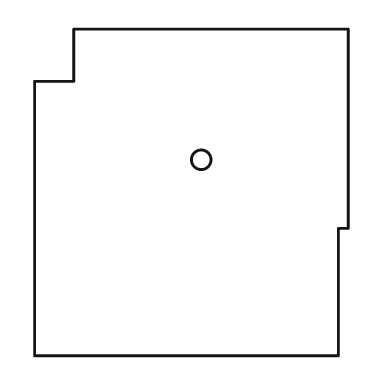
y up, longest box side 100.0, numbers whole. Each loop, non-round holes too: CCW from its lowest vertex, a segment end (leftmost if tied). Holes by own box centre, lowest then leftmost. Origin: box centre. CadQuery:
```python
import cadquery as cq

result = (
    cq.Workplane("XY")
    .moveTo(-48.0, -50.0)
    .lineTo(45.0, -50.0)
    .lineTo(45.0, -11.0)
    .lineTo(48.0, -11.0)
    .lineTo(48.0, 50.0)
    .lineTo(-36.0, 50.0)
    .lineTo(-36.0, 34.0)
    .lineTo(-48.0, 34.0)
    .close()
    .moveTo(3.0, 10.0)
    .circle(3.0)
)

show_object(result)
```